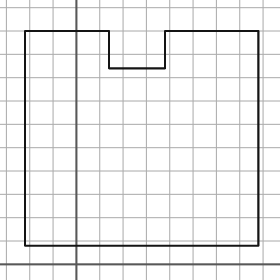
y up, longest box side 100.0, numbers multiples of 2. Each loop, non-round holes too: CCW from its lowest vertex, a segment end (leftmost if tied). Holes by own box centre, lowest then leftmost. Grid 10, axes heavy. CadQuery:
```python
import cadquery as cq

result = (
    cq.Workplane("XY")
    .moveTo(-22.0, 8.0)
    .lineTo(78.0, 8.0)
    .lineTo(78.0, 100.0)
    .lineTo(38.0, 100.0)
    .lineTo(38.0, 84.0)
    .lineTo(14.0, 84.0)
    .lineTo(14.0, 100.0)
    .lineTo(-22.0, 100.0)
    .close()
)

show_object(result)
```